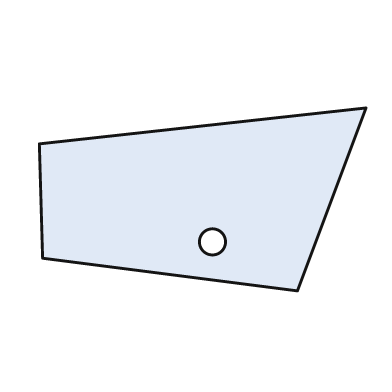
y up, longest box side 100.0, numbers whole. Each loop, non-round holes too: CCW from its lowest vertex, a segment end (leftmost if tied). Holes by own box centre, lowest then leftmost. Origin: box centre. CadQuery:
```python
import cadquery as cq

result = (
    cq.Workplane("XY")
    .moveTo(29.0, -28.0)
    .lineTo(50.0, 28.0)
    .lineTo(-50.0, 17.0)
    .lineTo(-49.0, -18.0)
    .close()
    .moveTo(3.0, -13.0)
    .circle(4.0)
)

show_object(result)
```